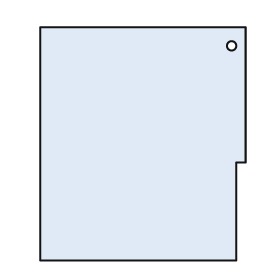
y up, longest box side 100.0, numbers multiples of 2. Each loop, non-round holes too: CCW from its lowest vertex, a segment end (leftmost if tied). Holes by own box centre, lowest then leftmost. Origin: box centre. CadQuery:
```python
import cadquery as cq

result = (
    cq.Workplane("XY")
    .moveTo(-44.0, -50.0)
    .lineTo(40.0, -50.0)
    .lineTo(40.0, -8.0)
    .lineTo(44.0, -8.0)
    .lineTo(44.0, 50.0)
    .lineTo(-44.0, 50.0)
    .close()
    .moveTo(38.0, 42.0)
    .circle(2.0)
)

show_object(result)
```